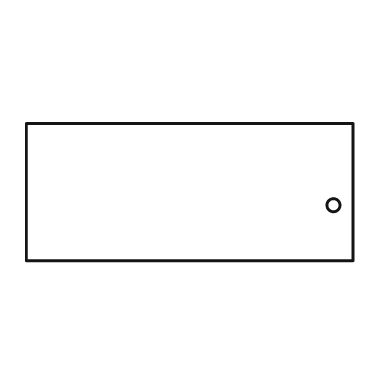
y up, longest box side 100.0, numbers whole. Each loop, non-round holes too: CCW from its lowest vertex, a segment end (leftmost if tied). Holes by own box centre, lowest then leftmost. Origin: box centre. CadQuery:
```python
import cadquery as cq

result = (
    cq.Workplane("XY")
    .moveTo(-50.0, -21.0)
    .lineTo(50.0, -21.0)
    .lineTo(50.0, 21.0)
    .lineTo(-50.0, 21.0)
    .close()
    .moveTo(44.0, -4.0)
    .circle(2.0)
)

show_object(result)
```